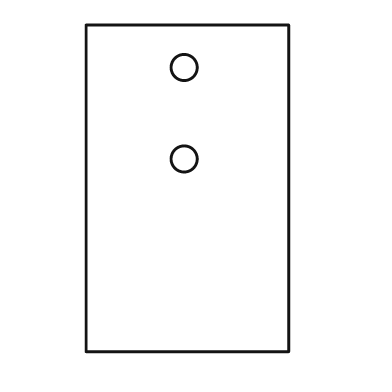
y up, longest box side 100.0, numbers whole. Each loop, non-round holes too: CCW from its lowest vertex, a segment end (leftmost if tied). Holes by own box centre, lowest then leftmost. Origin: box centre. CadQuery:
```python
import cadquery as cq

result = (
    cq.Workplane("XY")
    .moveTo(-31.0, -50.0)
    .lineTo(31.0, -50.0)
    .lineTo(31.0, 50.0)
    .lineTo(-31.0, 50.0)
    .close()
    .moveTo(-1.0, 9.0)
    .circle(4.0)
    .moveTo(-1.0, 37.0)
    .circle(4.0)
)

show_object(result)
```